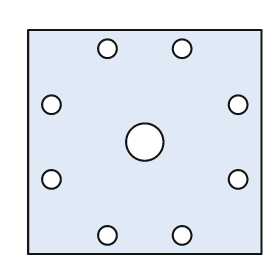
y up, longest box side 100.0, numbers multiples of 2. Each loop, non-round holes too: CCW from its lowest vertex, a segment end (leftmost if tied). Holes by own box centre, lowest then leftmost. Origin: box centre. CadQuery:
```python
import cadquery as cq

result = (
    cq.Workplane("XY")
    .moveTo(-50.0, -48.0)
    .lineTo(50.0, -48.0)
    .lineTo(50.0, 48.0)
    .lineTo(-50.0, 48.0)
    .close()
    .moveTo(-16.0, -40.0)
    .circle(4.0)
    .moveTo(16.0, -40.0)
    .circle(4.0)
    .moveTo(-40.0, -16.0)
    .circle(4.0)
    .moveTo(40.0, -16.0)
    .circle(4.0)
    .moveTo(0.0, 0.0)
    .circle(8.0)
    .moveTo(-40.0, 16.0)
    .circle(4.0)
    .moveTo(40.0, 16.0)
    .circle(4.0)
    .moveTo(-16.0, 40.0)
    .circle(4.0)
    .moveTo(16.0, 40.0)
    .circle(4.0)
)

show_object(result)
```